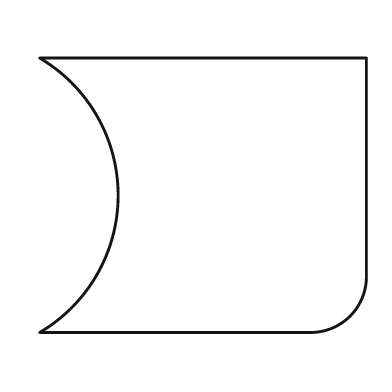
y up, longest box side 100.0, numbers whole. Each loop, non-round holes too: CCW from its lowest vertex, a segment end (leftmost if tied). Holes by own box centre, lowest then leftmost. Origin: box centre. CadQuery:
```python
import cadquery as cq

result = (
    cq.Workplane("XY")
    .moveTo(-50.0, -42.0)
    .lineTo(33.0, -42.0)
    .threePointArc((45.0, -37.0), (50.0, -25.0))
    .lineTo(50.0, 42.0)
    .lineTo(-50.0, 42.0)
    .threePointArc((-26.0, 0.0), (-50.0, -42.0))
    .close()
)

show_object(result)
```